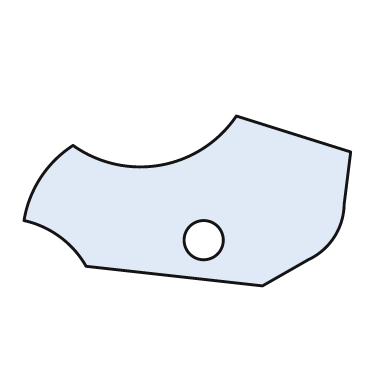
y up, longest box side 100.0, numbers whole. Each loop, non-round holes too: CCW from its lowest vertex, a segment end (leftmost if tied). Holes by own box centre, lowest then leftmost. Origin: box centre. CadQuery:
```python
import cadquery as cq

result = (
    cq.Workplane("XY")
    .moveTo(23.0, -26.0)
    .lineTo(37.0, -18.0)
    .threePointArc((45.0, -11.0), (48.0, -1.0))
    .lineTo(50.0, 15.0)
    .lineTo(15.0, 26.0)
    .threePointArc((-8.0, 11.0), (-35.0, 17.0))
    .threePointArc((-45.0, 7.0), (-50.0, -6.0))
    .threePointArc((-39.0, -11.0), (-31.0, -20.0))
    .close()
    .moveTo(5.0, -12.0)
    .circle(6.0)
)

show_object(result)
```